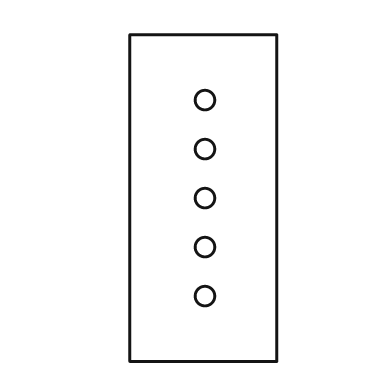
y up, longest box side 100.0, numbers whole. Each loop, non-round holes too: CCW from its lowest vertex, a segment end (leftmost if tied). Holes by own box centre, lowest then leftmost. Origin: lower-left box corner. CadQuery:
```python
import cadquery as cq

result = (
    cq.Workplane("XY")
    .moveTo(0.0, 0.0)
    .lineTo(45.0, 0.0)
    .lineTo(45.0, 100.0)
    .lineTo(0.0, 100.0)
    .close()
    .moveTo(23.0, 20.0)
    .circle(3.0)
    .moveTo(23.0, 35.0)
    .circle(3.0)
    .moveTo(23.0, 50.0)
    .circle(3.0)
    .moveTo(23.0, 65.0)
    .circle(3.0)
    .moveTo(23.0, 80.0)
    .circle(3.0)
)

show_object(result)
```